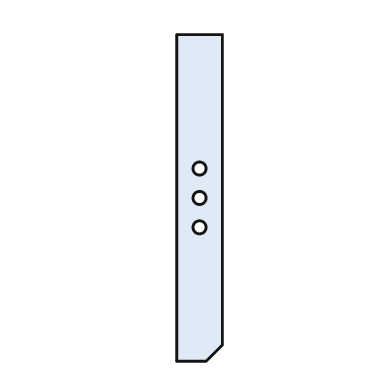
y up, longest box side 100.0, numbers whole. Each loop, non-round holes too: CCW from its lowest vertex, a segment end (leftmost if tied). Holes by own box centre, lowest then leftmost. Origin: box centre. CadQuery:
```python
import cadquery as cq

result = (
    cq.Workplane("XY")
    .moveTo(-7.0, -50.0)
    .lineTo(2.0, -50.0)
    .lineTo(7.0, -45.0)
    .lineTo(7.0, 50.0)
    .lineTo(-7.0, 50.0)
    .close()
    .moveTo(0.0, -9.0)
    .circle(2.0)
    .moveTo(0.0, 0.0)
    .circle(2.0)
    .moveTo(0.0, 9.0)
    .circle(2.0)
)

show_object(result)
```